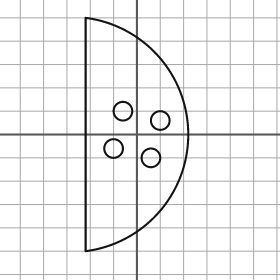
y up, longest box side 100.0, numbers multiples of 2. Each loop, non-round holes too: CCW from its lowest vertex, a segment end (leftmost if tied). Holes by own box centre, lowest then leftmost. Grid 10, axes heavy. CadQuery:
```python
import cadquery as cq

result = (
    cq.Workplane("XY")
    .moveTo(-22.0, -50.0)
    .threePointArc((22.0, 0.0), (-22.0, 50.0))
    .close()
    .moveTo(6.0, -10.0)
    .circle(4.0)
    .moveTo(-10.0, -6.0)
    .circle(4.0)
    .moveTo(10.0, 6.0)
    .circle(4.0)
    .moveTo(-6.0, 10.0)
    .circle(4.0)
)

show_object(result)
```